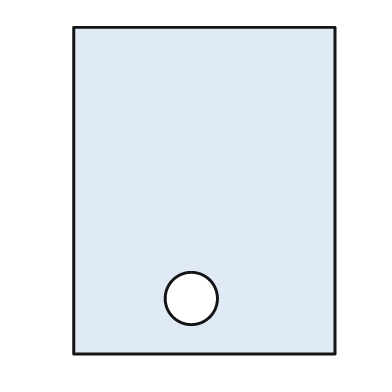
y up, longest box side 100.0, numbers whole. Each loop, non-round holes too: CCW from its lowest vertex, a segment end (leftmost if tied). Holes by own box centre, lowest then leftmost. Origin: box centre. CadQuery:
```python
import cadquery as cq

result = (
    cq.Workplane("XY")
    .moveTo(-40.0, -50.0)
    .lineTo(40.0, -50.0)
    .lineTo(40.0, 50.0)
    .lineTo(-40.0, 50.0)
    .close()
    .moveTo(-4.0, -33.0)
    .circle(8.0)
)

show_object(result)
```